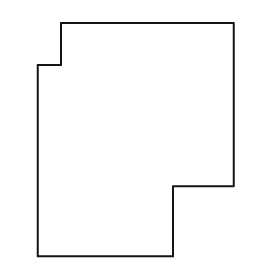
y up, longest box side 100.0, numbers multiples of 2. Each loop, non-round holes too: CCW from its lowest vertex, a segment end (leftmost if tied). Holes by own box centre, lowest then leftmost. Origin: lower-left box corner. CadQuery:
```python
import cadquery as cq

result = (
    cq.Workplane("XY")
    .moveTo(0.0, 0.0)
    .lineTo(58.0, 0.0)
    .lineTo(58.0, 30.0)
    .lineTo(84.0, 30.0)
    .lineTo(84.0, 100.0)
    .lineTo(10.0, 100.0)
    .lineTo(10.0, 82.0)
    .lineTo(0.0, 82.0)
    .close()
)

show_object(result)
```